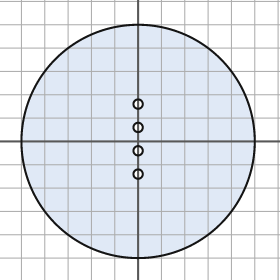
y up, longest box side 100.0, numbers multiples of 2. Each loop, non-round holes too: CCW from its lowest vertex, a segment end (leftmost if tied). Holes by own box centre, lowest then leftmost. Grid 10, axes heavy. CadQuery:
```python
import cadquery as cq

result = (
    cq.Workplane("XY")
    .moveTo(0.0, 0.0)
    .circle(50.0)
    .moveTo(0.0, -14.0)
    .circle(2.0)
    .moveTo(0.0, -4.0)
    .circle(2.0)
    .moveTo(0.0, 6.0)
    .circle(2.0)
    .moveTo(0.0, 16.0)
    .circle(2.0)
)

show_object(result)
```